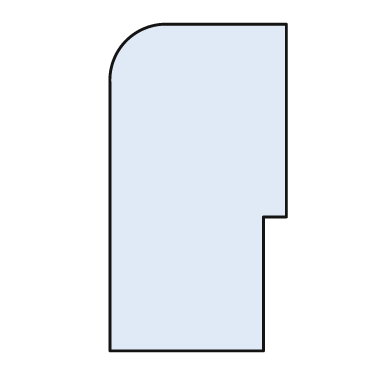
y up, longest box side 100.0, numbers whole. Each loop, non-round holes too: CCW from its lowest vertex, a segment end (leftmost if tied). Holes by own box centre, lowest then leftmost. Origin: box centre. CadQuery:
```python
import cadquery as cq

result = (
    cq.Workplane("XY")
    .moveTo(-27.0, -50.0)
    .lineTo(20.0, -50.0)
    .lineTo(20.0, -9.0)
    .lineTo(27.0, -9.0)
    .lineTo(27.0, 50.0)
    .lineTo(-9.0, 50.0)
    .threePointArc((-22.0, 45.0), (-27.0, 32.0))
    .close()
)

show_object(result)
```